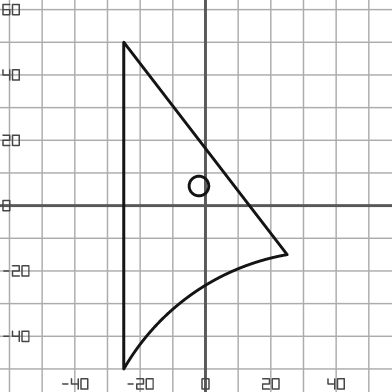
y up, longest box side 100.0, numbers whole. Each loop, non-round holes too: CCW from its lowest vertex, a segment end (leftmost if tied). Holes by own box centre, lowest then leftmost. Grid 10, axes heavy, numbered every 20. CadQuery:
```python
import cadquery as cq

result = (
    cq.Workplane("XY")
    .moveTo(-25.0, -50.0)
    .threePointArc((-4.0, -27.0), (25.0, -15.0))
    .lineTo(-25.0, 50.0)
    .close()
    .moveTo(-2.0, 6.0)
    .circle(3.0)
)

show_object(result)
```